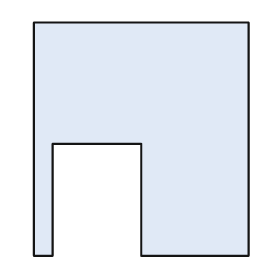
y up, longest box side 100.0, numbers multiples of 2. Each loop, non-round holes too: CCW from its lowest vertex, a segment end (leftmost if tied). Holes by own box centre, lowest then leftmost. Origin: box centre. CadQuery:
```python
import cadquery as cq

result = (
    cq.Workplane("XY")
    .moveTo(-46.0, -50.0)
    .lineTo(-38.0, -50.0)
    .lineTo(-38.0, -2.0)
    .lineTo(0.0, -2.0)
    .lineTo(0.0, -50.0)
    .lineTo(46.0, -50.0)
    .lineTo(46.0, 50.0)
    .lineTo(-46.0, 50.0)
    .close()
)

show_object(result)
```